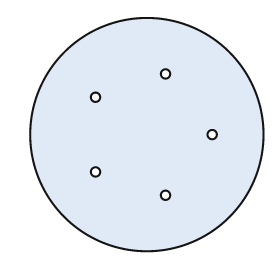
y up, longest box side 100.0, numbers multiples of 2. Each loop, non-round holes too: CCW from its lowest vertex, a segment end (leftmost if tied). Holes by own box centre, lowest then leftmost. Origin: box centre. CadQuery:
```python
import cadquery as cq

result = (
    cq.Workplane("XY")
    .moveTo(0.0, 0.0)
    .circle(50.0)
    .moveTo(8.0, -26.0)
    .circle(2.0)
    .moveTo(-22.0, -16.0)
    .circle(2.0)
    .moveTo(28.0, 0.0)
    .circle(2.0)
    .moveTo(-22.0, 16.0)
    .circle(2.0)
    .moveTo(8.0, 26.0)
    .circle(2.0)
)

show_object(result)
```